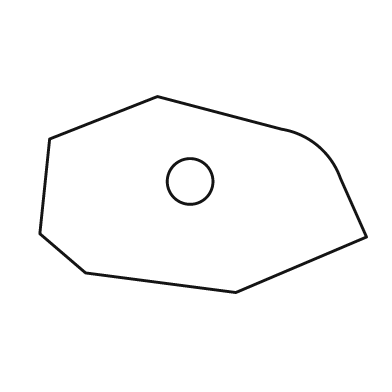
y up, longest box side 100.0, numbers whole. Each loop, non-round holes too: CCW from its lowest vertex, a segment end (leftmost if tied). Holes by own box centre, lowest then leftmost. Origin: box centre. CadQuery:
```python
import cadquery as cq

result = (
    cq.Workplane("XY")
    .moveTo(10.0, -30.0)
    .lineTo(50.0, -13.0)
    .lineTo(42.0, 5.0)
    .threePointArc((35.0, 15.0), (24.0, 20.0))
    .lineTo(-14.0, 30.0)
    .lineTo(-47.0, 17.0)
    .lineTo(-50.0, -12.0)
    .lineTo(-36.0, -24.0)
    .close()
    .moveTo(-4.0, 4.0)
    .circle(7.0)
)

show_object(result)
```